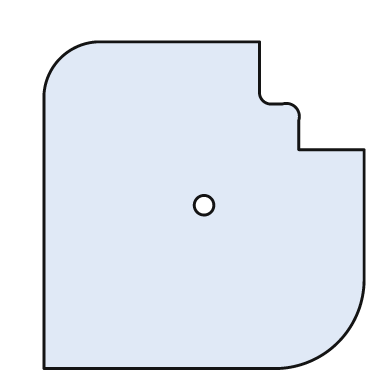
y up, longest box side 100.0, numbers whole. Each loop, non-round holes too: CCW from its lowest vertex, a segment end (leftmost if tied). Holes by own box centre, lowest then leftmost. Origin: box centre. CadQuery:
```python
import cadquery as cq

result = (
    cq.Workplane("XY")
    .moveTo(-49.0, -50.0)
    .lineTo(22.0, -50.0)
    .threePointArc((41.0, -42.0), (49.0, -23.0))
    .lineTo(49.0, 17.0)
    .lineTo(29.0, 17.0)
    .lineTo(29.0, 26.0)
    .threePointArc((28.0, 30.0), (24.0, 31.0))
    .lineTo(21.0, 31.0)
    .threePointArc((18.0, 32.0), (17.0, 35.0))
    .lineTo(17.0, 50.0)
    .lineTo(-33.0, 50.0)
    .threePointArc((-44.0, 45.0), (-49.0, 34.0))
    .close()
    .moveTo(0.0, 0.0)
    .circle(3.0)
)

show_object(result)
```